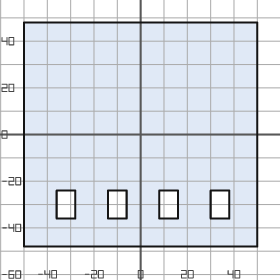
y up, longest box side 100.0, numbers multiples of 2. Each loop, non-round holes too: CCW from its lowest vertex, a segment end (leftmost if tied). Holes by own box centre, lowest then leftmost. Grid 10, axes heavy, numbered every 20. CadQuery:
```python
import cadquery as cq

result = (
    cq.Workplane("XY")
    .moveTo(-50.0, -48.0)
    .lineTo(50.0, -48.0)
    .lineTo(50.0, 48.0)
    .lineTo(-50.0, 48.0)
    .close()
    .moveTo(-36.0, -36.0)
    .lineTo(-28.0, -36.0)
    .lineTo(-28.0, -24.0)
    .lineTo(-36.0, -24.0)
    .close()
    .moveTo(-14.0, -36.0)
    .lineTo(-6.0, -36.0)
    .lineTo(-6.0, -24.0)
    .lineTo(-14.0, -24.0)
    .close()
    .moveTo(8.0, -36.0)
    .lineTo(16.0, -36.0)
    .lineTo(16.0, -24.0)
    .lineTo(8.0, -24.0)
    .close()
    .moveTo(30.0, -36.0)
    .lineTo(38.0, -36.0)
    .lineTo(38.0, -24.0)
    .lineTo(30.0, -24.0)
    .close()
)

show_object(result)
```